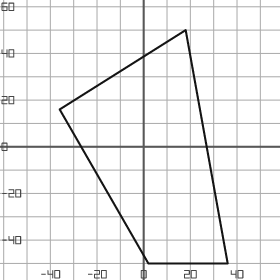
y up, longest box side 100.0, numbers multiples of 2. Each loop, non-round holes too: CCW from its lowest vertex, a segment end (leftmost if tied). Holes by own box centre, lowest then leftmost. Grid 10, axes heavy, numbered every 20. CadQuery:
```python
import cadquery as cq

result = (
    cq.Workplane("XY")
    .moveTo(2.0, -50.0)
    .lineTo(36.0, -50.0)
    .lineTo(18.0, 50.0)
    .lineTo(-36.0, 16.0)
    .close()
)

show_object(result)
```